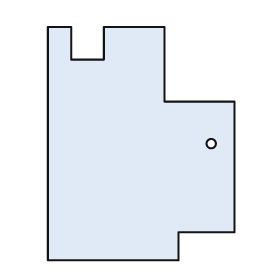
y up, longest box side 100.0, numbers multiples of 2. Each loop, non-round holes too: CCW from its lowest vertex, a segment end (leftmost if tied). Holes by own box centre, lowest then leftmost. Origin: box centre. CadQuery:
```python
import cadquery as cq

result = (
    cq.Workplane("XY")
    .moveTo(-40.0, -50.0)
    .lineTo(16.0, -50.0)
    .lineTo(16.0, -38.0)
    .lineTo(40.0, -38.0)
    .lineTo(40.0, 18.0)
    .lineTo(10.0, 18.0)
    .lineTo(10.0, 50.0)
    .lineTo(-16.0, 50.0)
    .lineTo(-16.0, 36.0)
    .lineTo(-30.0, 36.0)
    .lineTo(-30.0, 50.0)
    .lineTo(-40.0, 50.0)
    .close()
    .moveTo(30.0, 0.0)
    .circle(2.0)
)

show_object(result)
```